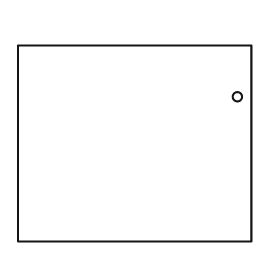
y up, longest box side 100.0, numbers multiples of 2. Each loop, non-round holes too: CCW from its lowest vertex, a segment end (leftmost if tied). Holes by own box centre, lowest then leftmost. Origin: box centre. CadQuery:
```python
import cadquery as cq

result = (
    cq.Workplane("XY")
    .moveTo(-50.0, -42.0)
    .lineTo(50.0, -42.0)
    .lineTo(50.0, 42.0)
    .lineTo(-50.0, 42.0)
    .close()
    .moveTo(44.0, 20.0)
    .circle(2.0)
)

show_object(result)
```